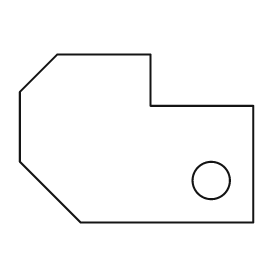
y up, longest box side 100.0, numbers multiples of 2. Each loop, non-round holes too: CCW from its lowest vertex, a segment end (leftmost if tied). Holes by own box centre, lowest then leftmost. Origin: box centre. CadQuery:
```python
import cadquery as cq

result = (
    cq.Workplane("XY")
    .moveTo(-24.0, -36.0)
    .lineTo(50.0, -36.0)
    .lineTo(50.0, 14.0)
    .lineTo(6.0, 14.0)
    .lineTo(6.0, 36.0)
    .lineTo(-34.0, 36.0)
    .lineTo(-50.0, 20.0)
    .lineTo(-50.0, -10.0)
    .close()
    .moveTo(32.0, -18.0)
    .circle(8.0)
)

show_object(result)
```